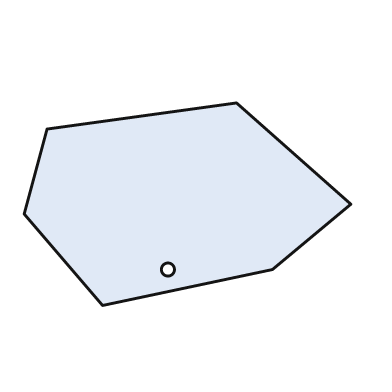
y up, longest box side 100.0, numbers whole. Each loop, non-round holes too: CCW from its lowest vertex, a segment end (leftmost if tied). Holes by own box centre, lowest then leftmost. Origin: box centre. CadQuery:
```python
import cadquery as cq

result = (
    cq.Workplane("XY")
    .moveTo(-26.0, -31.0)
    .lineTo(26.0, -20.0)
    .lineTo(50.0, 0.0)
    .lineTo(15.0, 31.0)
    .lineTo(-43.0, 23.0)
    .lineTo(-50.0, -3.0)
    .close()
    .moveTo(-6.0, -20.0)
    .circle(2.0)
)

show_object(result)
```